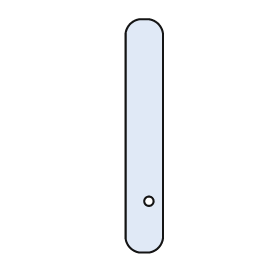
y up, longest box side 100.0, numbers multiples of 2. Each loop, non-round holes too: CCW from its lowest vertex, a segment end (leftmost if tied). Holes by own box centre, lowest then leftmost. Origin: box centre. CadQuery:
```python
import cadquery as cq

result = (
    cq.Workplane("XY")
    .moveTo(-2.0, -50.0)
    .lineTo(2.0, -50.0)
    .threePointArc((6.0, -48.0), (8.0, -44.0))
    .lineTo(8.0, 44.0)
    .threePointArc((6.0, 48.0), (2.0, 50.0))
    .lineTo(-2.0, 50.0)
    .threePointArc((-6.0, 48.0), (-8.0, 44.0))
    .lineTo(-8.0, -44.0)
    .threePointArc((-6.0, -48.0), (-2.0, -50.0))
    .close()
    .moveTo(2.0, -28.0)
    .circle(2.0)
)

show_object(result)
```